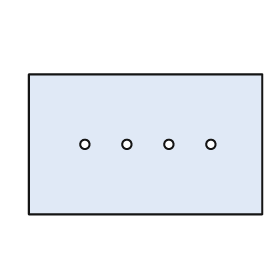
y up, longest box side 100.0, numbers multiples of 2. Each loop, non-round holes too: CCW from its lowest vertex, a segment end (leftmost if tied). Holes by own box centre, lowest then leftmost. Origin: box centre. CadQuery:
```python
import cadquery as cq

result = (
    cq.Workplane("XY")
    .moveTo(-50.0, -30.0)
    .lineTo(50.0, -30.0)
    .lineTo(50.0, 30.0)
    .lineTo(-50.0, 30.0)
    .close()
    .moveTo(-26.0, 0.0)
    .circle(2.0)
    .moveTo(-8.0, 0.0)
    .circle(2.0)
    .moveTo(10.0, 0.0)
    .circle(2.0)
    .moveTo(28.0, 0.0)
    .circle(2.0)
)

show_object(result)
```